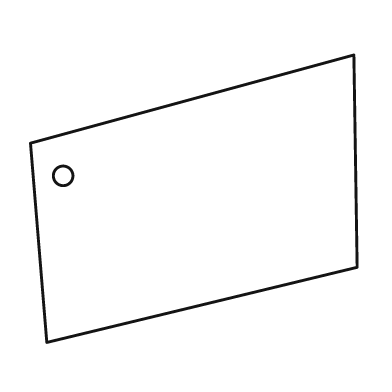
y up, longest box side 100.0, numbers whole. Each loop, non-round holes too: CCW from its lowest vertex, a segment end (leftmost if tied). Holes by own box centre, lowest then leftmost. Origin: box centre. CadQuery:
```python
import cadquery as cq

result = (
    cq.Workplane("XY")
    .moveTo(-45.0, -44.0)
    .lineTo(50.0, -21.0)
    .lineTo(49.0, 44.0)
    .lineTo(-50.0, 17.0)
    .close()
    .moveTo(-40.0, 7.0)
    .circle(3.0)
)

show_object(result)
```